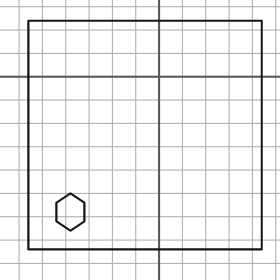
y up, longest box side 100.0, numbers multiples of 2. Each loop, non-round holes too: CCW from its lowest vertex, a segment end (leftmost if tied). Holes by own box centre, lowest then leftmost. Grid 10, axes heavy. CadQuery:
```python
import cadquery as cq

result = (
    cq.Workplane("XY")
    .moveTo(-56.0, -74.0)
    .lineTo(44.0, -74.0)
    .lineTo(44.0, 24.0)
    .lineTo(-56.0, 24.0)
    .close()
    .moveTo(-38.0, -66.0)
    .lineTo(-32.0, -62.0)
    .lineTo(-32.0, -54.0)
    .lineTo(-38.0, -50.0)
    .lineTo(-44.0, -54.0)
    .lineTo(-44.0, -62.0)
    .close()
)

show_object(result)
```